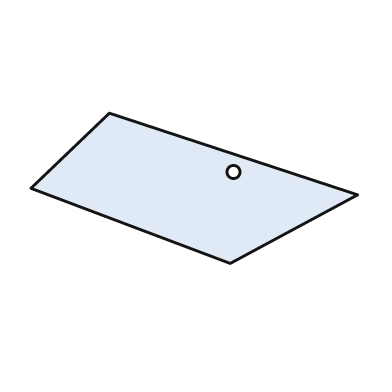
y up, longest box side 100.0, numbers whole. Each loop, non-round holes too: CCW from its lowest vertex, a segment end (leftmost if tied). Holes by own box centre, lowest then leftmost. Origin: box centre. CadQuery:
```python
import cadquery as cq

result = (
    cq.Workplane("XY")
    .moveTo(11.0, -23.0)
    .lineTo(50.0, -2.0)
    .lineTo(-26.0, 23.0)
    .lineTo(-50.0, 0.0)
    .close()
    .moveTo(12.0, 5.0)
    .circle(2.0)
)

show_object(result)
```